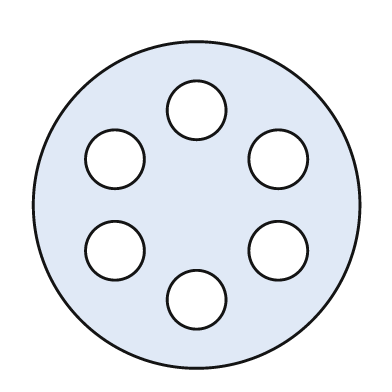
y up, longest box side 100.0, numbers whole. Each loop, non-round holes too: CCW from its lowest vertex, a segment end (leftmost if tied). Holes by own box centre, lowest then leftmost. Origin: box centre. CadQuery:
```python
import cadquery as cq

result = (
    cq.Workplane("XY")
    .moveTo(0.0, 0.0)
    .circle(50.0)
    .moveTo(0.0, -29.0)
    .circle(9.0)
    .moveTo(-25.0, -14.0)
    .circle(9.0)
    .moveTo(25.0, -14.0)
    .circle(9.0)
    .moveTo(-25.0, 14.0)
    .circle(9.0)
    .moveTo(25.0, 14.0)
    .circle(9.0)
    .moveTo(0.0, 29.0)
    .circle(9.0)
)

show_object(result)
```